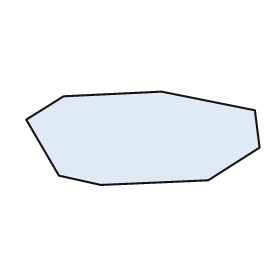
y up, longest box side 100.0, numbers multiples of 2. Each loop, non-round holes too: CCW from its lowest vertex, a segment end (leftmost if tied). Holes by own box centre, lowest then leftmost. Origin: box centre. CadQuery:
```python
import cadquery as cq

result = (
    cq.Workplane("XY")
    .moveTo(-18.0, -20.0)
    .lineTo(28.0, -18.0)
    .lineTo(50.0, -4.0)
    .lineTo(48.0, 12.0)
    .lineTo(8.0, 20.0)
    .lineTo(-34.0, 18.0)
    .lineTo(-50.0, 8.0)
    .lineTo(-36.0, -16.0)
    .close()
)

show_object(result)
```